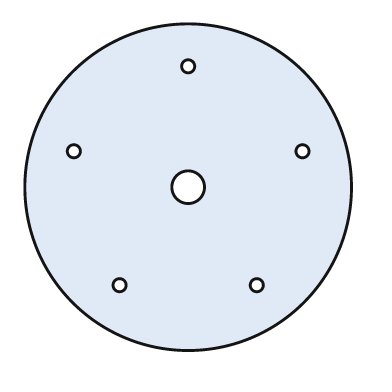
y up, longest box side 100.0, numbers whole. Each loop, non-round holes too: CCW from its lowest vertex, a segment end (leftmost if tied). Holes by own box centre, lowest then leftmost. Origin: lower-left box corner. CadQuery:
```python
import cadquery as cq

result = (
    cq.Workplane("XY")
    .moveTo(50.0, 50.0)
    .circle(50.0)
    .moveTo(29.0, 20.0)
    .circle(2.0)
    .moveTo(71.0, 20.0)
    .circle(2.0)
    .moveTo(50.0, 50.0)
    .circle(5.0)
    .moveTo(15.0, 61.0)
    .circle(2.0)
    .moveTo(85.0, 61.0)
    .circle(2.0)
    .moveTo(50.0, 87.0)
    .circle(2.0)
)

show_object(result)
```